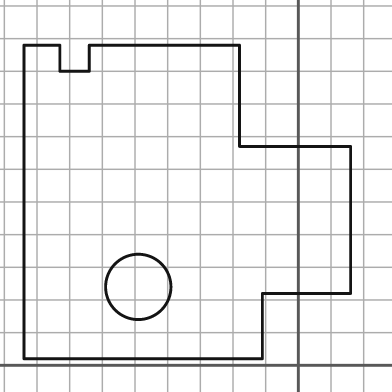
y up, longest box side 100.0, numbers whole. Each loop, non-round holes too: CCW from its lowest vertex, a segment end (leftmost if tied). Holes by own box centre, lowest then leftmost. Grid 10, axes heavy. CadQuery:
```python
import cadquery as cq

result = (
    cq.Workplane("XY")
    .moveTo(-84.0, 2.0)
    .lineTo(-11.0, 2.0)
    .lineTo(-11.0, 22.0)
    .lineTo(16.0, 22.0)
    .lineTo(16.0, 67.0)
    .lineTo(-18.0, 67.0)
    .lineTo(-18.0, 98.0)
    .lineTo(-64.0, 98.0)
    .lineTo(-64.0, 90.0)
    .lineTo(-73.0, 90.0)
    .lineTo(-73.0, 98.0)
    .lineTo(-84.0, 98.0)
    .close()
    .moveTo(-49.0, 24.0)
    .circle(10.0)
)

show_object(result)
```